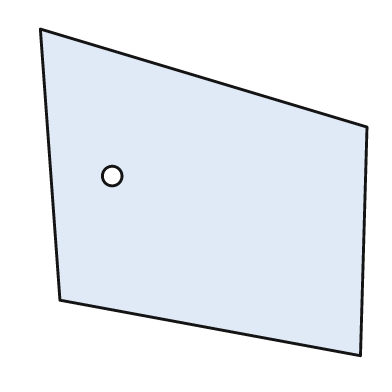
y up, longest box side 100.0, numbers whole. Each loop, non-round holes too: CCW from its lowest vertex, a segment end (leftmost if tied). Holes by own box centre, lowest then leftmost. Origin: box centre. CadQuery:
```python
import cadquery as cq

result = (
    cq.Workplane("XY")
    .moveTo(48.0, -50.0)
    .lineTo(50.0, 20.0)
    .lineTo(-50.0, 50.0)
    .lineTo(-44.0, -33.0)
    .close()
    .moveTo(-28.0, 5.0)
    .circle(3.0)
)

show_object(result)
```